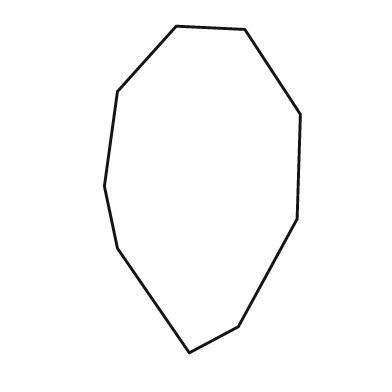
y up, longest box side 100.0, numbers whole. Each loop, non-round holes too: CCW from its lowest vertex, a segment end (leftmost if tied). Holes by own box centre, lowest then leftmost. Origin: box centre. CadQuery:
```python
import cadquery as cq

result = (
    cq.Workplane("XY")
    .moveTo(-4.0, -50.0)
    .lineTo(11.0, -42.0)
    .lineTo(29.0, -9.0)
    .lineTo(30.0, 23.0)
    .lineTo(13.0, 49.0)
    .lineTo(-8.0, 50.0)
    .lineTo(-26.0, 30.0)
    .lineTo(-30.0, 1.0)
    .lineTo(-26.0, -18.0)
    .close()
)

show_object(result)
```